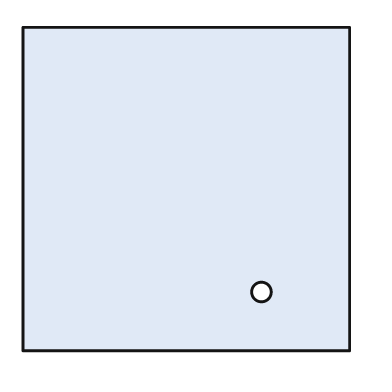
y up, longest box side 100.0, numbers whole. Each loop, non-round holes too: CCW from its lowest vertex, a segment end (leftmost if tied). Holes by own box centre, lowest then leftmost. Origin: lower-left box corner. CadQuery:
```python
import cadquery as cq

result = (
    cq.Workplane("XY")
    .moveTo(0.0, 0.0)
    .lineTo(100.0, 0.0)
    .lineTo(100.0, 99.0)
    .lineTo(0.0, 99.0)
    .close()
    .moveTo(73.0, 18.0)
    .circle(3.0)
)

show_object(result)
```